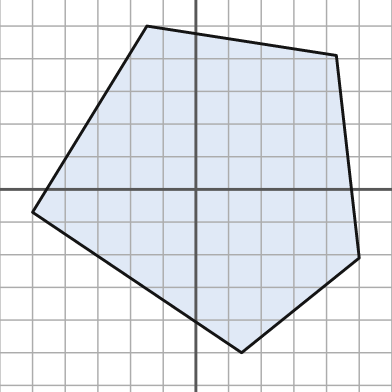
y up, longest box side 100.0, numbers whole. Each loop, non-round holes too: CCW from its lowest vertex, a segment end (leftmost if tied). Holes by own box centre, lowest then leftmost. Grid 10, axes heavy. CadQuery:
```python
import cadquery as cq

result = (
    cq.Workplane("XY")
    .moveTo(14.0, -50.0)
    .lineTo(50.0, -21.0)
    .lineTo(43.0, 41.0)
    .lineTo(-15.0, 50.0)
    .lineTo(-50.0, -7.0)
    .close()
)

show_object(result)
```